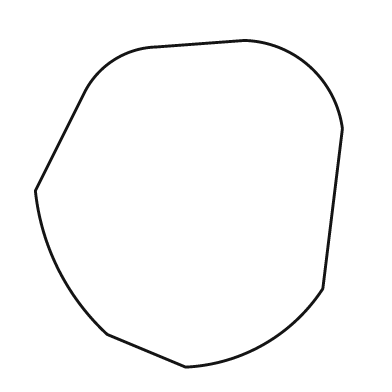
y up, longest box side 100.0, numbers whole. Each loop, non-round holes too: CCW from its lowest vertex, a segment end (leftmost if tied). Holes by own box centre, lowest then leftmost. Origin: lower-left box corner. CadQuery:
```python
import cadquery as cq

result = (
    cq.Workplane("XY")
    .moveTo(46.0, 0.0)
    .threePointArc((70.0, 7.0), (88.0, 24.0))
    .lineTo(94.0, 73.0)
    .threePointArc((84.0, 92.0), (64.0, 100.0))
    .lineTo(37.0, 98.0)
    .threePointArc((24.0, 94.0), (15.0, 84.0))
    .lineTo(0.0, 54.0)
    .threePointArc((7.0, 30.0), (22.0, 10.0))
    .close()
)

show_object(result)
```